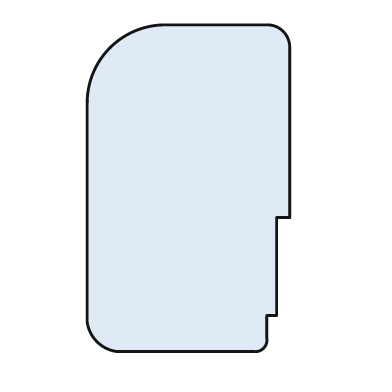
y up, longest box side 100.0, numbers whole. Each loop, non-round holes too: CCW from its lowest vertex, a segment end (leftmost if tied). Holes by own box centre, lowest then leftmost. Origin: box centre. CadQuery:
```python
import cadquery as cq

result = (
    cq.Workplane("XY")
    .moveTo(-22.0, -50.0)
    .lineTo(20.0, -50.0)
    .threePointArc((23.0, -49.0), (24.0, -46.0))
    .lineTo(24.0, -39.0)
    .lineTo(27.0, -39.0)
    .lineTo(27.0, -9.0)
    .lineTo(31.0, -9.0)
    .lineTo(31.0, 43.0)
    .threePointArc((29.0, 48.0), (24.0, 50.0))
    .lineTo(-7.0, 50.0)
    .threePointArc((-24.0, 43.0), (-31.0, 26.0))
    .lineTo(-31.0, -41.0)
    .threePointArc((-28.0, -47.0), (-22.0, -50.0))
    .close()
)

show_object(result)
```